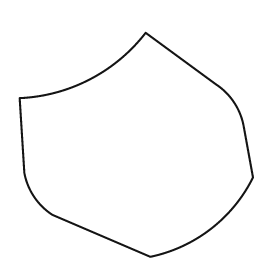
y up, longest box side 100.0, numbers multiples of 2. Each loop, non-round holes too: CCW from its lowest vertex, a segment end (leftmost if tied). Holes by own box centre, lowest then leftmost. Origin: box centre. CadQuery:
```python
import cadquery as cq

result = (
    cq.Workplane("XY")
    .moveTo(6.0, -48.0)
    .threePointArc((32.0, -36.0), (50.0, -14.0))
    .lineTo(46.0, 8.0)
    .threePointArc((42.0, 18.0), (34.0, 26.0))
    .lineTo(4.0, 48.0)
    .threePointArc((-20.0, 28.0), (-50.0, 20.0))
    .lineTo(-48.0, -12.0)
    .threePointArc((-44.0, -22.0), (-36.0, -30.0))
    .close()
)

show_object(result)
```